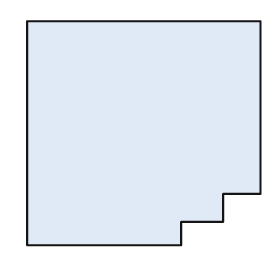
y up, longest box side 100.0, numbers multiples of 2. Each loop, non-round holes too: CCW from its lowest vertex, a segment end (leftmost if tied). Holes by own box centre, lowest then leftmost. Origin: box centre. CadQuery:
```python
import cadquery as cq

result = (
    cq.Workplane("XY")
    .moveTo(-50.0, -48.0)
    .lineTo(16.0, -48.0)
    .lineTo(16.0, -38.0)
    .lineTo(34.0, -38.0)
    .lineTo(34.0, -26.0)
    .lineTo(50.0, -26.0)
    .lineTo(50.0, 48.0)
    .lineTo(-50.0, 48.0)
    .close()
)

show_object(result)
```